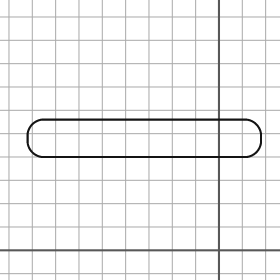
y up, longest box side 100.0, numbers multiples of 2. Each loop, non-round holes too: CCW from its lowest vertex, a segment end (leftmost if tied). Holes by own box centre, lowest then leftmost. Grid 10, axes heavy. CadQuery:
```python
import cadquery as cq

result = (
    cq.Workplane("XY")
    .moveTo(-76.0, 40.0)
    .lineTo(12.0, 40.0)
    .threePointArc((16.0, 42.0), (18.0, 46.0))
    .lineTo(18.0, 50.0)
    .threePointArc((16.0, 54.0), (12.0, 56.0))
    .lineTo(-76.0, 56.0)
    .threePointArc((-80.0, 54.0), (-82.0, 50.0))
    .lineTo(-82.0, 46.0)
    .threePointArc((-80.0, 42.0), (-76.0, 40.0))
    .close()
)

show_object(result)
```